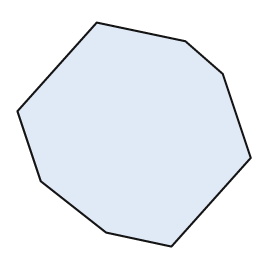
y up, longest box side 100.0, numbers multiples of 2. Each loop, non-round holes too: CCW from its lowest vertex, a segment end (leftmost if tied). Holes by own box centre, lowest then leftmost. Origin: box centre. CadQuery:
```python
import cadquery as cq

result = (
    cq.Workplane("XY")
    .moveTo(16.0, -48.0)
    .lineTo(50.0, -10.0)
    .lineTo(38.0, 26.0)
    .lineTo(22.0, 40.0)
    .lineTo(-16.0, 48.0)
    .lineTo(-50.0, 10.0)
    .lineTo(-40.0, -20.0)
    .lineTo(-12.0, -42.0)
    .close()
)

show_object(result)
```